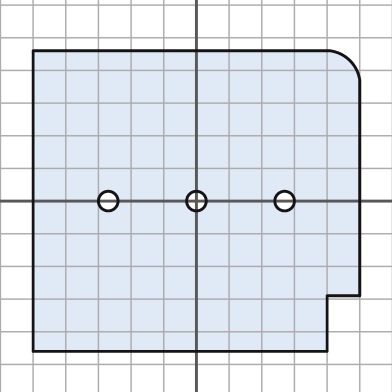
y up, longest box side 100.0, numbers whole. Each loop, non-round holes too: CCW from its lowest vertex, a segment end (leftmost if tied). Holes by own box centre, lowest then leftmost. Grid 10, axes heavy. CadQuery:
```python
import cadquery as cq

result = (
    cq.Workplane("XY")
    .moveTo(-50.0, -46.0)
    .lineTo(40.0, -46.0)
    .lineTo(40.0, -29.0)
    .lineTo(50.0, -29.0)
    .lineTo(50.0, 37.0)
    .threePointArc((47.0, 43.0), (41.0, 46.0))
    .lineTo(-50.0, 46.0)
    .close()
    .moveTo(-27.0, 0.0)
    .circle(3.0)
    .moveTo(0.0, 0.0)
    .circle(3.0)
    .moveTo(27.0, 0.0)
    .circle(3.0)
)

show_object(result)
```